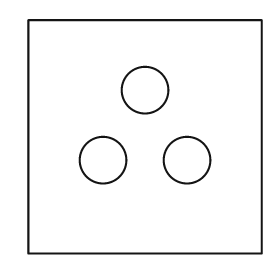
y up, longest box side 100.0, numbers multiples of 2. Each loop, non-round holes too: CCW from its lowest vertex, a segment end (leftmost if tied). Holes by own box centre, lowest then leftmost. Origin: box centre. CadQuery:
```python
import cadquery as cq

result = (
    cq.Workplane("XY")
    .moveTo(-50.0, -50.0)
    .lineTo(50.0, -50.0)
    .lineTo(50.0, 50.0)
    .lineTo(-50.0, 50.0)
    .close()
    .moveTo(-18.0, -10.0)
    .circle(10.0)
    .moveTo(18.0, -10.0)
    .circle(10.0)
    .moveTo(0.0, 20.0)
    .circle(10.0)
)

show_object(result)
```